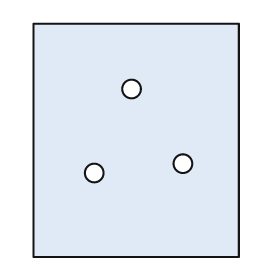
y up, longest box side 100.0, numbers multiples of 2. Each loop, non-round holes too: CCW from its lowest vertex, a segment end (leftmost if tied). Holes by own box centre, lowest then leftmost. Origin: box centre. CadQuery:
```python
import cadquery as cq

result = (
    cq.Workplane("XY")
    .moveTo(-44.0, -50.0)
    .lineTo(44.0, -50.0)
    .lineTo(44.0, 50.0)
    .lineTo(-44.0, 50.0)
    .close()
    .moveTo(-18.0, -14.0)
    .circle(4.0)
    .moveTo(20.0, -10.0)
    .circle(4.0)
    .moveTo(-2.0, 22.0)
    .circle(4.0)
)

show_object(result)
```